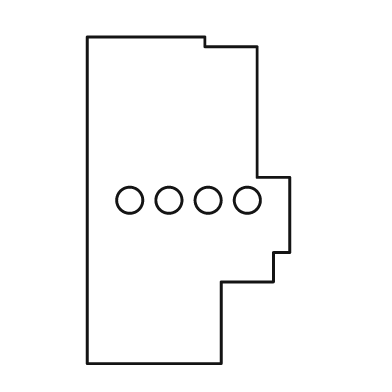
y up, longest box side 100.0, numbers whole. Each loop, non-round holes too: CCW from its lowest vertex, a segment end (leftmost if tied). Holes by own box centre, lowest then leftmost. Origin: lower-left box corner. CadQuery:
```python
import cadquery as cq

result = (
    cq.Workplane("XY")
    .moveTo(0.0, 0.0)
    .lineTo(41.0, 0.0)
    .lineTo(41.0, 25.0)
    .lineTo(57.0, 25.0)
    .lineTo(57.0, 34.0)
    .lineTo(62.0, 34.0)
    .lineTo(62.0, 57.0)
    .lineTo(52.0, 57.0)
    .lineTo(52.0, 97.0)
    .lineTo(36.0, 97.0)
    .lineTo(36.0, 100.0)
    .lineTo(0.0, 100.0)
    .close()
    .moveTo(13.0, 50.0)
    .circle(4.0)
    .moveTo(25.0, 50.0)
    .circle(4.0)
    .moveTo(37.0, 50.0)
    .circle(4.0)
    .moveTo(49.0, 50.0)
    .circle(4.0)
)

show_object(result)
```